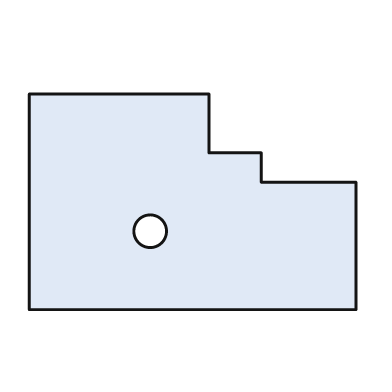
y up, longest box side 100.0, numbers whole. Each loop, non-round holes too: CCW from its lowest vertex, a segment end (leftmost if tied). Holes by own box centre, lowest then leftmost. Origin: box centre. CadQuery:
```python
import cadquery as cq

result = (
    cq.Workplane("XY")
    .moveTo(-50.0, -33.0)
    .lineTo(50.0, -33.0)
    .lineTo(50.0, 6.0)
    .lineTo(21.0, 6.0)
    .lineTo(21.0, 15.0)
    .lineTo(5.0, 15.0)
    .lineTo(5.0, 33.0)
    .lineTo(-50.0, 33.0)
    .close()
    .moveTo(-13.0, -9.0)
    .circle(5.0)
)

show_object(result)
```